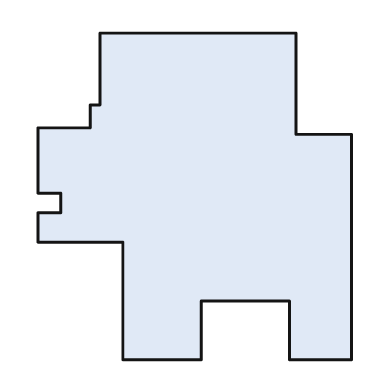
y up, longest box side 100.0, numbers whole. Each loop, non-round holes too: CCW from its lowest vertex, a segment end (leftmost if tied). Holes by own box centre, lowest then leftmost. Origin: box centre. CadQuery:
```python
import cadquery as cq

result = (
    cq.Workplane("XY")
    .moveTo(-22.0, -50.0)
    .lineTo(2.0, -50.0)
    .lineTo(2.0, -32.0)
    .lineTo(29.0, -32.0)
    .lineTo(29.0, -50.0)
    .lineTo(48.0, -50.0)
    .lineTo(48.0, 19.0)
    .lineTo(31.0, 19.0)
    .lineTo(31.0, 50.0)
    .lineTo(-29.0, 50.0)
    .lineTo(-29.0, 28.0)
    .lineTo(-32.0, 28.0)
    .lineTo(-32.0, 21.0)
    .lineTo(-48.0, 21.0)
    .lineTo(-48.0, 1.0)
    .lineTo(-41.0, 1.0)
    .lineTo(-41.0, -5.0)
    .lineTo(-48.0, -5.0)
    .lineTo(-48.0, -14.0)
    .lineTo(-22.0, -14.0)
    .close()
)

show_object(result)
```